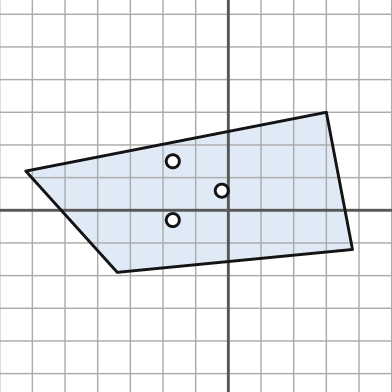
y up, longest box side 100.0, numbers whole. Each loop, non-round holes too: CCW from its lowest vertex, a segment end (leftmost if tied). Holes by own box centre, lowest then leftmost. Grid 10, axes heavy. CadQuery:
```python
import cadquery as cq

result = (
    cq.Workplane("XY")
    .moveTo(-34.0, -19.0)
    .lineTo(38.0, -12.0)
    .lineTo(30.0, 30.0)
    .lineTo(-62.0, 12.0)
    .close()
    .moveTo(-17.0, -3.0)
    .circle(2.0)
    .moveTo(-2.0, 6.0)
    .circle(2.0)
    .moveTo(-17.0, 15.0)
    .circle(2.0)
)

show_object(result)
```